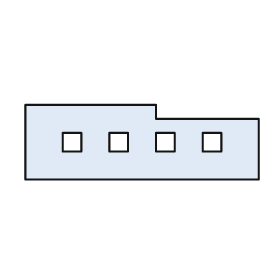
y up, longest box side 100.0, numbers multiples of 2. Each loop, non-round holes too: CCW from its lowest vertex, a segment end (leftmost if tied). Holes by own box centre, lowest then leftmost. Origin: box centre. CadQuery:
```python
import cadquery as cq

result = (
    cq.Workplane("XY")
    .moveTo(-50.0, -16.0)
    .lineTo(50.0, -16.0)
    .lineTo(50.0, 10.0)
    .lineTo(6.0, 10.0)
    .lineTo(6.0, 16.0)
    .lineTo(-50.0, 16.0)
    .close()
    .moveTo(-34.0, -4.0)
    .lineTo(-26.0, -4.0)
    .lineTo(-26.0, 4.0)
    .lineTo(-34.0, 4.0)
    .close()
    .moveTo(-14.0, -4.0)
    .lineTo(-6.0, -4.0)
    .lineTo(-6.0, 4.0)
    .lineTo(-14.0, 4.0)
    .close()
    .moveTo(6.0, -4.0)
    .lineTo(14.0, -4.0)
    .lineTo(14.0, 4.0)
    .lineTo(6.0, 4.0)
    .close()
    .moveTo(26.0, -4.0)
    .lineTo(34.0, -4.0)
    .lineTo(34.0, 4.0)
    .lineTo(26.0, 4.0)
    .close()
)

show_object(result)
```